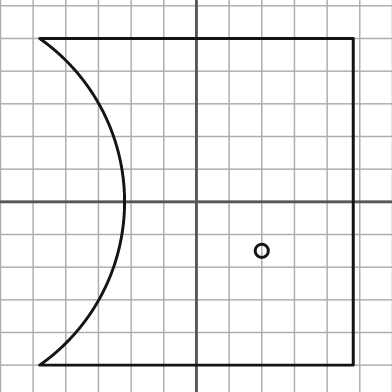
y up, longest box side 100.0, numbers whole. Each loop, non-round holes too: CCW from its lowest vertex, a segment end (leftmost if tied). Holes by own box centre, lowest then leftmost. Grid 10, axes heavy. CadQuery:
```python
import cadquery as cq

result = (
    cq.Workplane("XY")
    .moveTo(-48.0, -50.0)
    .lineTo(48.0, -50.0)
    .lineTo(48.0, 50.0)
    .lineTo(-48.0, 50.0)
    .threePointArc((-22.0, 0.0), (-48.0, -50.0))
    .close()
    .moveTo(20.0, -15.0)
    .circle(2.0)
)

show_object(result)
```